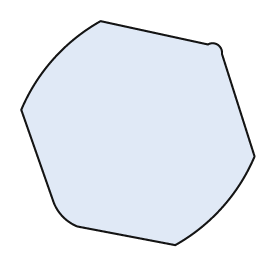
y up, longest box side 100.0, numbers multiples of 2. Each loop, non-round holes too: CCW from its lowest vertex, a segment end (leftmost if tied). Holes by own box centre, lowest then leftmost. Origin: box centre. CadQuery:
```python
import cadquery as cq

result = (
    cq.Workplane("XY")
    .moveTo(16.0, -48.0)
    .threePointArc((36.0, -32.0), (50.0, -10.0))
    .lineTo(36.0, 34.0)
    .threePointArc((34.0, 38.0), (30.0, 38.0))
    .lineTo(-16.0, 48.0)
    .threePointArc((-36.0, 32.0), (-50.0, 10.0))
    .lineTo(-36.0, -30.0)
    .threePointArc((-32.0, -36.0), (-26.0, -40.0))
    .close()
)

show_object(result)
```